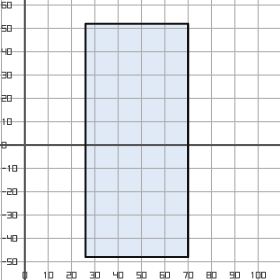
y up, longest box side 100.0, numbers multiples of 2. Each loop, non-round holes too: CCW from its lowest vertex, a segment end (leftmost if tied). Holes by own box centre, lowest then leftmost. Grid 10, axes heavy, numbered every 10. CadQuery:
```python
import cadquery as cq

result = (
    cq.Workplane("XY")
    .moveTo(26.0, -48.0)
    .lineTo(70.0, -48.0)
    .lineTo(70.0, 52.0)
    .lineTo(26.0, 52.0)
    .close()
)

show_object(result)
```